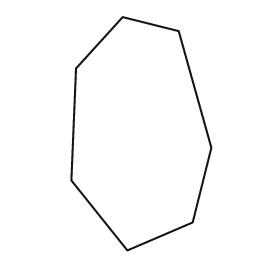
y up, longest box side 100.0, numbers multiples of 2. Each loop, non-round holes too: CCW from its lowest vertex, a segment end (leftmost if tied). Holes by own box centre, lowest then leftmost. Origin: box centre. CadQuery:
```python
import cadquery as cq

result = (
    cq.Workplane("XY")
    .moveTo(-6.0, -50.0)
    .lineTo(22.0, -38.0)
    .lineTo(30.0, -6.0)
    .lineTo(16.0, 44.0)
    .lineTo(-8.0, 50.0)
    .lineTo(-28.0, 28.0)
    .lineTo(-30.0, -20.0)
    .close()
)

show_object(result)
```